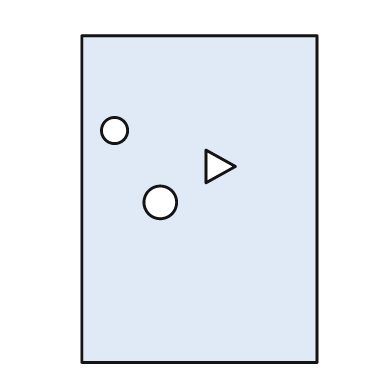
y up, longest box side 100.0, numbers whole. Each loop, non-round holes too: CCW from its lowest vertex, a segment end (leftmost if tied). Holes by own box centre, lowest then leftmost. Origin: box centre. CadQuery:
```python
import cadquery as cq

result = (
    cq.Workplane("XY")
    .moveTo(-36.0, -50.0)
    .lineTo(36.0, -50.0)
    .lineTo(36.0, 50.0)
    .lineTo(-36.0, 50.0)
    .close()
    .moveTo(-12.0, -1.0)
    .circle(5.0)
    .moveTo(2.0, 5.0)
    .lineTo(11.0, 10.0)
    .lineTo(2.0, 15.0)
    .close()
    .moveTo(-26.0, 21.0)
    .circle(4.0)
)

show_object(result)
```